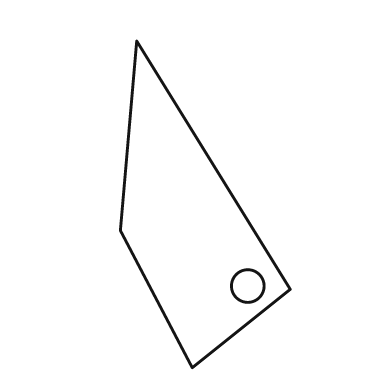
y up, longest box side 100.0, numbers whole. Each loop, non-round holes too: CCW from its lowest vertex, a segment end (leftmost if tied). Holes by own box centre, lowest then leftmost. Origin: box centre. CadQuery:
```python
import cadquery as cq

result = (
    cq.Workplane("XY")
    .moveTo(-4.0, -50.0)
    .lineTo(26.0, -26.0)
    .lineTo(-21.0, 50.0)
    .lineTo(-26.0, -8.0)
    .close()
    .moveTo(13.0, -25.0)
    .circle(5.0)
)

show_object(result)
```